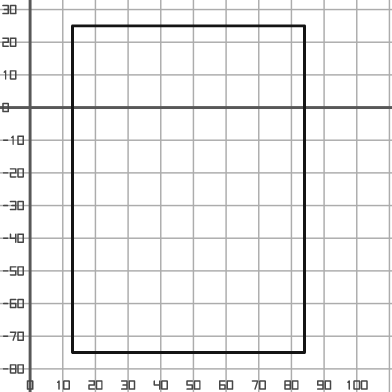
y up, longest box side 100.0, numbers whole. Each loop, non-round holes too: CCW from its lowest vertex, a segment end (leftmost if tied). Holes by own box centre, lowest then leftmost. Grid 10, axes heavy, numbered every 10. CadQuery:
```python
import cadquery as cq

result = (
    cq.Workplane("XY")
    .moveTo(13.0, -75.0)
    .lineTo(84.0, -75.0)
    .lineTo(84.0, 25.0)
    .lineTo(13.0, 25.0)
    .close()
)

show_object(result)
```